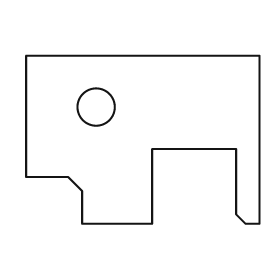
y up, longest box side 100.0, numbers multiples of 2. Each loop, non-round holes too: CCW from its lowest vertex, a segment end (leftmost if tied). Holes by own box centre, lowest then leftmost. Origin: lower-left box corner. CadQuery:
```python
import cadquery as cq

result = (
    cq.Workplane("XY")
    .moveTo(24.0, 0.0)
    .lineTo(54.0, 0.0)
    .lineTo(54.0, 32.0)
    .lineTo(90.0, 32.0)
    .lineTo(90.0, 4.0)
    .lineTo(94.0, 0.0)
    .lineTo(100.0, 0.0)
    .lineTo(100.0, 72.0)
    .lineTo(0.0, 72.0)
    .lineTo(0.0, 20.0)
    .lineTo(18.0, 20.0)
    .lineTo(24.0, 14.0)
    .close()
    .moveTo(30.0, 50.0)
    .circle(8.0)
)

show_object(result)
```